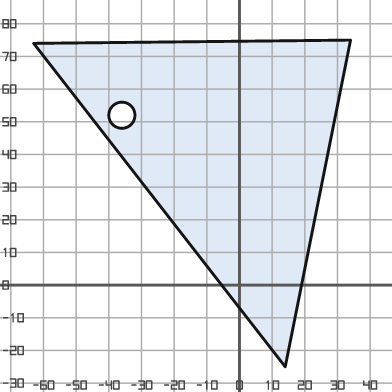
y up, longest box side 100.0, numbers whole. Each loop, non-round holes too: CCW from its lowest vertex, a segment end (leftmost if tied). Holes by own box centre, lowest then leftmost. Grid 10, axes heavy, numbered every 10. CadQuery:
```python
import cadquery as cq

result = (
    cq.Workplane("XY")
    .moveTo(14.0, -25.0)
    .lineTo(34.0, 75.0)
    .lineTo(-63.0, 74.0)
    .close()
    .moveTo(-36.0, 52.0)
    .circle(4.0)
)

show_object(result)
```